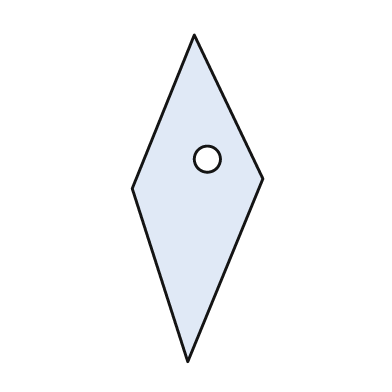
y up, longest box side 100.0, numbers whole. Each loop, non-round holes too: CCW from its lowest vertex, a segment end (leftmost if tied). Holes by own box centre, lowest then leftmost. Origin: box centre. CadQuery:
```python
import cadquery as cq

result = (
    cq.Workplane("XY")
    .moveTo(-3.0, -50.0)
    .lineTo(20.0, 6.0)
    .lineTo(-1.0, 50.0)
    .lineTo(-20.0, 3.0)
    .close()
    .moveTo(3.0, 12.0)
    .circle(4.0)
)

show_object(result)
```